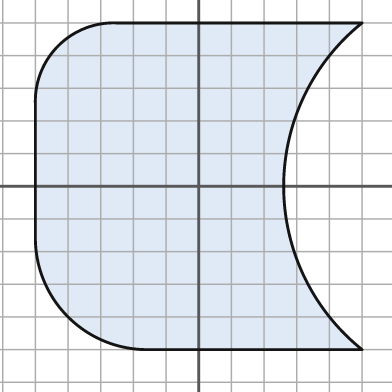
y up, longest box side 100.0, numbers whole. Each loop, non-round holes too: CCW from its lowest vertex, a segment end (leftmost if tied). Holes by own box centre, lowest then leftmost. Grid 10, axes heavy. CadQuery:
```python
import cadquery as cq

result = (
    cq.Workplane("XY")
    .moveTo(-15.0, -50.0)
    .lineTo(50.0, -50.0)
    .threePointArc((26.0, 0.0), (50.0, 50.0))
    .lineTo(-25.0, 50.0)
    .threePointArc((-43.0, 43.0), (-50.0, 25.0))
    .lineTo(-50.0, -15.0)
    .threePointArc((-40.0, -40.0), (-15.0, -50.0))
    .close()
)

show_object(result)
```